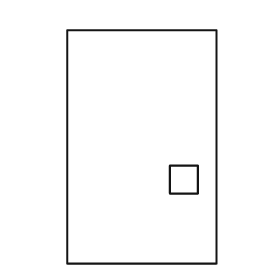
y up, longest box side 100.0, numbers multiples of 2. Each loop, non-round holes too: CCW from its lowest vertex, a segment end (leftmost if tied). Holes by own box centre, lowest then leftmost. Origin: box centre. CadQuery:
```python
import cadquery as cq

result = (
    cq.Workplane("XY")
    .moveTo(-32.0, -50.0)
    .lineTo(32.0, -50.0)
    .lineTo(32.0, 50.0)
    .lineTo(-32.0, 50.0)
    .close()
    .moveTo(12.0, -20.0)
    .lineTo(24.0, -20.0)
    .lineTo(24.0, -8.0)
    .lineTo(12.0, -8.0)
    .close()
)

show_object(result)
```